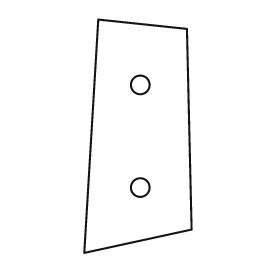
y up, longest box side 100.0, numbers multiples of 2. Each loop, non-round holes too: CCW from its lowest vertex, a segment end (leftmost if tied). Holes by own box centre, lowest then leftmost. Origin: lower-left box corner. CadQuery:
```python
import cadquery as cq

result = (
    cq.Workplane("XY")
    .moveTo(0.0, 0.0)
    .lineTo(46.0, 10.0)
    .lineTo(44.0, 96.0)
    .lineTo(6.0, 100.0)
    .close()
    .moveTo(24.0, 28.0)
    .circle(4.0)
    .moveTo(24.0, 72.0)
    .circle(4.0)
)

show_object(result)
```